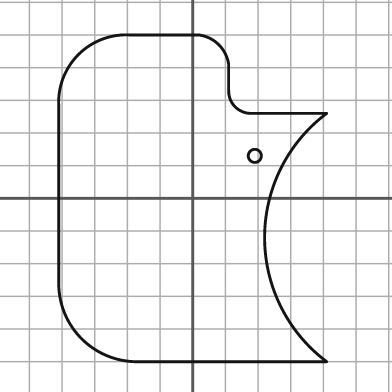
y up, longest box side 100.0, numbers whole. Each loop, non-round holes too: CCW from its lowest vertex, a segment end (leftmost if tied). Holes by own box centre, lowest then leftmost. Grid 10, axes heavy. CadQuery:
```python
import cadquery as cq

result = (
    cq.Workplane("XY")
    .moveTo(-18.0, -50.0)
    .lineTo(41.0, -50.0)
    .threePointArc((22.0, -12.0), (41.0, 26.0))
    .lineTo(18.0, 26.0)
    .threePointArc((13.0, 28.0), (11.0, 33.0))
    .lineTo(11.0, 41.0)
    .threePointArc((8.0, 47.0), (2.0, 50.0))
    .lineTo(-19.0, 50.0)
    .threePointArc((-35.0, 44.0), (-41.0, 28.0))
    .lineTo(-41.0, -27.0)
    .threePointArc((-34.0, -43.0), (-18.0, -50.0))
    .close()
    .moveTo(19.0, 13.0)
    .circle(2.0)
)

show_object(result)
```